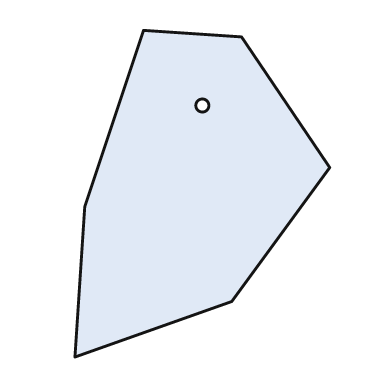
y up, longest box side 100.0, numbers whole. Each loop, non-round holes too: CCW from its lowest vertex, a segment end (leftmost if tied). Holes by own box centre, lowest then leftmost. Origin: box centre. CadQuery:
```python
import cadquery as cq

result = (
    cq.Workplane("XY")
    .moveTo(-39.0, -50.0)
    .lineTo(9.0, -33.0)
    .lineTo(39.0, 8.0)
    .lineTo(12.0, 48.0)
    .lineTo(-18.0, 50.0)
    .lineTo(-36.0, -4.0)
    .close()
    .moveTo(0.0, 27.0)
    .circle(2.0)
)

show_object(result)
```